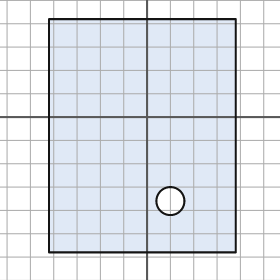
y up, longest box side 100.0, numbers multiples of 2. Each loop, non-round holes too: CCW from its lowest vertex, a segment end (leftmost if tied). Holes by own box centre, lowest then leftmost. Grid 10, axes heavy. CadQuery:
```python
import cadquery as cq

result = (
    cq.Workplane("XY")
    .moveTo(-42.0, -58.0)
    .lineTo(38.0, -58.0)
    .lineTo(38.0, 42.0)
    .lineTo(-42.0, 42.0)
    .close()
    .moveTo(10.0, -36.0)
    .circle(6.0)
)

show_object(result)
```